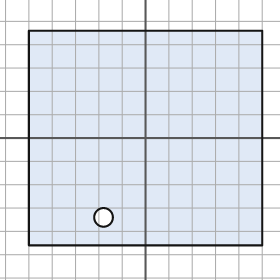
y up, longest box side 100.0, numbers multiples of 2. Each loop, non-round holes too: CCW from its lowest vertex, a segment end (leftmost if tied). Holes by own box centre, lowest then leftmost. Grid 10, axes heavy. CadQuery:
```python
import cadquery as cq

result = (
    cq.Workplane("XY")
    .moveTo(-50.0, -46.0)
    .lineTo(50.0, -46.0)
    .lineTo(50.0, 46.0)
    .lineTo(-50.0, 46.0)
    .close()
    .moveTo(-18.0, -34.0)
    .circle(4.0)
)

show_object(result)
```